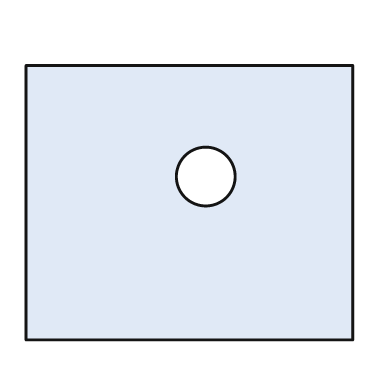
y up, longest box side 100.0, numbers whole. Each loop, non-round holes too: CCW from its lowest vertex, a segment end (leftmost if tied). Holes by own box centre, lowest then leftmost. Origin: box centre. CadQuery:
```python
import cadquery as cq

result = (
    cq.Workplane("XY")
    .moveTo(-50.0, -42.0)
    .lineTo(50.0, -42.0)
    .lineTo(50.0, 42.0)
    .lineTo(-50.0, 42.0)
    .close()
    .moveTo(5.0, 8.0)
    .circle(9.0)
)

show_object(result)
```